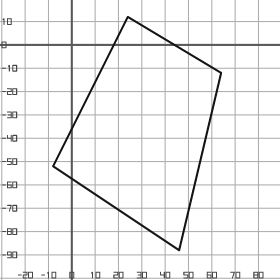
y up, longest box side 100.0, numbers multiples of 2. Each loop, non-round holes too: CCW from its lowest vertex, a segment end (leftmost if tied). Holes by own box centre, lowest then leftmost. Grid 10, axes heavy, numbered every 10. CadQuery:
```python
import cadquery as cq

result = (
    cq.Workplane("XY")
    .moveTo(46.0, -88.0)
    .lineTo(64.0, -12.0)
    .lineTo(24.0, 12.0)
    .lineTo(-8.0, -52.0)
    .close()
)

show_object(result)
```